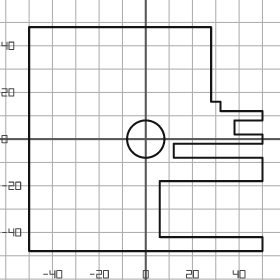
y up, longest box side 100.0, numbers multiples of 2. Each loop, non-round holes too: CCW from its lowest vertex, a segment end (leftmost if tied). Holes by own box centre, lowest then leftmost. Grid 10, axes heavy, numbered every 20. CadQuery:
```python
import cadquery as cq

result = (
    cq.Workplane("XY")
    .moveTo(-50.0, -48.0)
    .lineTo(50.0, -48.0)
    .lineTo(50.0, -42.0)
    .lineTo(6.0, -42.0)
    .lineTo(6.0, -18.0)
    .lineTo(50.0, -18.0)
    .lineTo(50.0, -8.0)
    .lineTo(12.0, -8.0)
    .lineTo(12.0, -2.0)
    .lineTo(50.0, -2.0)
    .lineTo(50.0, 2.0)
    .lineTo(38.0, 2.0)
    .lineTo(38.0, 8.0)
    .lineTo(50.0, 8.0)
    .lineTo(50.0, 12.0)
    .lineTo(32.0, 12.0)
    .lineTo(32.0, 16.0)
    .lineTo(28.0, 16.0)
    .lineTo(28.0, 48.0)
    .lineTo(-50.0, 48.0)
    .close()
    .moveTo(0.0, 0.0)
    .circle(8.0)
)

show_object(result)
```